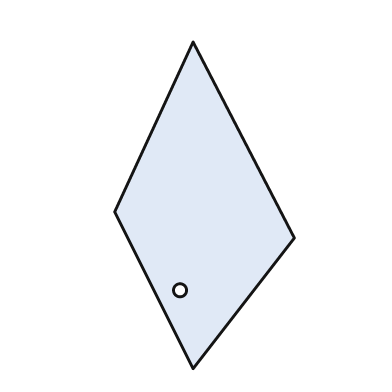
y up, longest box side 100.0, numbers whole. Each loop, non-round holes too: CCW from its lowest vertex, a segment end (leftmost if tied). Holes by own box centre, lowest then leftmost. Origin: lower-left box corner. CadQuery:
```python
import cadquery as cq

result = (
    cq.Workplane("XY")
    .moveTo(24.0, 0.0)
    .lineTo(55.0, 40.0)
    .lineTo(24.0, 100.0)
    .lineTo(0.0, 48.0)
    .close()
    .moveTo(20.0, 24.0)
    .circle(2.0)
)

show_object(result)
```